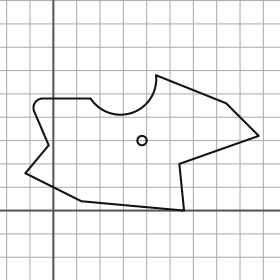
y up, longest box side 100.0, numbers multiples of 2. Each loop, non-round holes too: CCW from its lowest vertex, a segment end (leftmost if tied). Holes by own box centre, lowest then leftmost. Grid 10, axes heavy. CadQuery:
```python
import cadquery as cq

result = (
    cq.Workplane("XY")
    .moveTo(56.0, 0.0)
    .lineTo(54.0, 20.0)
    .lineTo(88.0, 32.0)
    .lineTo(74.0, 46.0)
    .lineTo(44.0, 58.0)
    .threePointArc((34.0, 42.0), (16.0, 48.0))
    .lineTo(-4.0, 48.0)
    .threePointArc((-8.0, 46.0), (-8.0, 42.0))
    .lineTo(-2.0, 28.0)
    .lineTo(-12.0, 16.0)
    .lineTo(12.0, 4.0)
    .close()
    .moveTo(38.0, 30.0)
    .circle(2.0)
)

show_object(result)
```